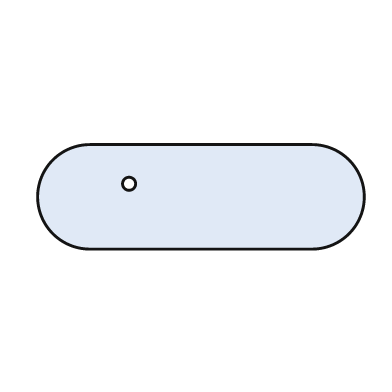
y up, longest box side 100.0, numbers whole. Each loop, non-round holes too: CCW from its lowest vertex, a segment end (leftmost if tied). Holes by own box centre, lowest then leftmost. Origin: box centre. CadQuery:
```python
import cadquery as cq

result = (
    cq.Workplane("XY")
    .moveTo(-34.0, -16.0)
    .lineTo(34.0, -16.0)
    .threePointArc((50.0, 0.0), (34.0, 16.0))
    .lineTo(-34.0, 16.0)
    .threePointArc((-50.0, 0.0), (-34.0, -16.0))
    .close()
    .moveTo(-22.0, 4.0)
    .circle(2.0)
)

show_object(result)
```